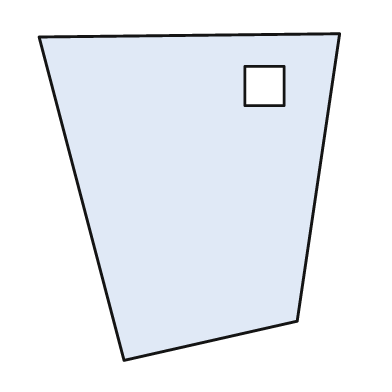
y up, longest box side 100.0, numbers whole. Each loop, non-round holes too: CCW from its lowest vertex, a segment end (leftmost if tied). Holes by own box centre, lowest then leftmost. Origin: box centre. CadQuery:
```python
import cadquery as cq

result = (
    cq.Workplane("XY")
    .moveTo(-20.0, -50.0)
    .lineTo(33.0, -38.0)
    .lineTo(46.0, 50.0)
    .lineTo(-46.0, 49.0)
    .close()
    .moveTo(17.0, 28.0)
    .lineTo(29.0, 28.0)
    .lineTo(29.0, 40.0)
    .lineTo(17.0, 40.0)
    .close()
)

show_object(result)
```